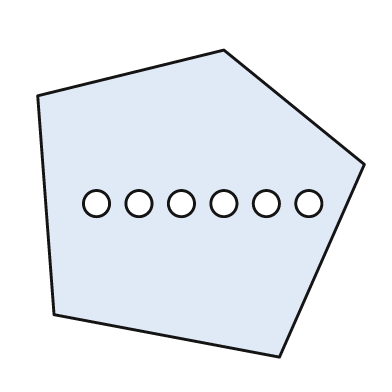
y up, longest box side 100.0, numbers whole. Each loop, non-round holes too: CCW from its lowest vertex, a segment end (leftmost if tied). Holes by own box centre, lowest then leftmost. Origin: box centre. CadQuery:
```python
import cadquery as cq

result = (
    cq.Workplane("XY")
    .moveTo(24.0, -47.0)
    .lineTo(50.0, 12.0)
    .lineTo(7.0, 47.0)
    .lineTo(-50.0, 33.0)
    .lineTo(-45.0, -34.0)
    .close()
    .moveTo(-32.0, 0.0)
    .circle(4.0)
    .moveTo(-19.0, 0.0)
    .circle(4.0)
    .moveTo(-6.0, 0.0)
    .circle(4.0)
    .moveTo(7.0, 0.0)
    .circle(4.0)
    .moveTo(20.0, 0.0)
    .circle(4.0)
    .moveTo(33.0, 0.0)
    .circle(4.0)
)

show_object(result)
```